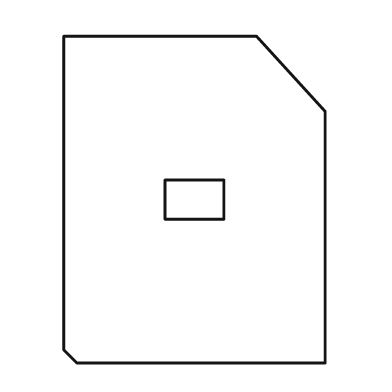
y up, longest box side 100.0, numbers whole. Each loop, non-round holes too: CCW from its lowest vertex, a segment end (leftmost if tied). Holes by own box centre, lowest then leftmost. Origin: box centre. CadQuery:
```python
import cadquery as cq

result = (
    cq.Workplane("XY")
    .moveTo(-36.0, -50.0)
    .lineTo(40.0, -50.0)
    .lineTo(40.0, 27.0)
    .lineTo(19.0, 50.0)
    .lineTo(-40.0, 50.0)
    .lineTo(-40.0, -46.0)
    .close()
    .moveTo(-9.0, -6.0)
    .lineTo(9.0, -6.0)
    .lineTo(9.0, 6.0)
    .lineTo(-9.0, 6.0)
    .close()
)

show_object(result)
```